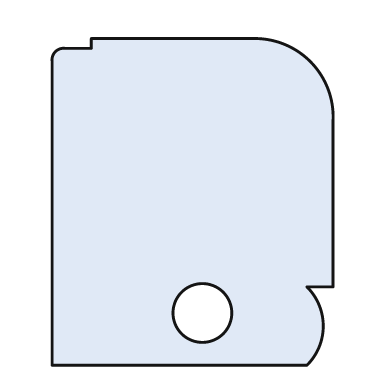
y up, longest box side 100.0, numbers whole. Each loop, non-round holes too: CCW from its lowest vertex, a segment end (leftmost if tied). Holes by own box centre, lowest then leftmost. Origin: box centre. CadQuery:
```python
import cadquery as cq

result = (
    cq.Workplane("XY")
    .moveTo(-43.0, -50.0)
    .lineTo(35.0, -50.0)
    .threePointArc((40.0, -38.0), (35.0, -26.0))
    .lineTo(43.0, -26.0)
    .lineTo(43.0, 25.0)
    .threePointArc((36.0, 43.0), (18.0, 50.0))
    .lineTo(-31.0, 50.0)
    .lineTo(-31.0, 47.0)
    .lineTo(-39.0, 47.0)
    .threePointArc((-42.0, 46.0), (-43.0, 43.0))
    .close()
    .moveTo(3.0, -34.0)
    .circle(9.0)
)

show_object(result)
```